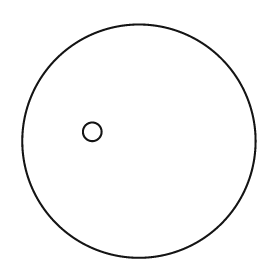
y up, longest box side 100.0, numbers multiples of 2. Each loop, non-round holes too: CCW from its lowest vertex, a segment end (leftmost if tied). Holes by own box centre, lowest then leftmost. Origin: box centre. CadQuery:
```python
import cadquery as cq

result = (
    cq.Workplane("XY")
    .moveTo(0.0, 0.0)
    .circle(50.0)
    .moveTo(-20.0, 4.0)
    .circle(4.0)
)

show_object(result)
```